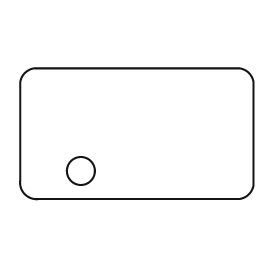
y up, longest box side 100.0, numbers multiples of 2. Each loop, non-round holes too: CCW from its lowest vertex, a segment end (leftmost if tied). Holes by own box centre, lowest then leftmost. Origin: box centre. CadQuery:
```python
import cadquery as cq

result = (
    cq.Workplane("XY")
    .moveTo(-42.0, -28.0)
    .lineTo(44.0, -28.0)
    .threePointArc((48.0, -26.0), (50.0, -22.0))
    .lineTo(50.0, 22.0)
    .threePointArc((48.0, 26.0), (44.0, 28.0))
    .lineTo(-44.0, 28.0)
    .threePointArc((-48.0, 26.0), (-50.0, 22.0))
    .lineTo(-50.0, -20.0)
    .threePointArc((-48.0, -26.0), (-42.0, -28.0))
    .close()
    .moveTo(-24.0, -16.0)
    .circle(6.0)
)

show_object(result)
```